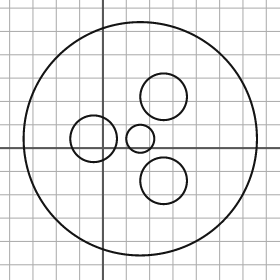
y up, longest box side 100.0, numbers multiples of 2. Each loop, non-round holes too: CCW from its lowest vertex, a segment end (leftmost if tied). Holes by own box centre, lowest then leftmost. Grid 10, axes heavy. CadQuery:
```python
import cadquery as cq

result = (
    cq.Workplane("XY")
    .moveTo(16.0, 4.0)
    .circle(50.0)
    .moveTo(26.0, -14.0)
    .circle(10.0)
    .moveTo(-4.0, 4.0)
    .circle(10.0)
    .moveTo(16.0, 4.0)
    .circle(6.0)
    .moveTo(26.0, 22.0)
    .circle(10.0)
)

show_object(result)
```